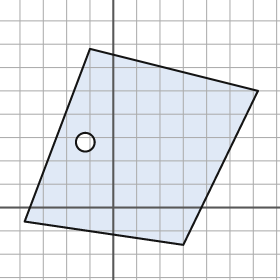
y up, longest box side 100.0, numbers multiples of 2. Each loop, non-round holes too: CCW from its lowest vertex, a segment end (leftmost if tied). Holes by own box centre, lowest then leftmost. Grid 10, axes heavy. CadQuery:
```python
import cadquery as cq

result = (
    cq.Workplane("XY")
    .moveTo(30.0, -16.0)
    .lineTo(62.0, 50.0)
    .lineTo(-10.0, 68.0)
    .lineTo(-38.0, -6.0)
    .close()
    .moveTo(-12.0, 28.0)
    .circle(4.0)
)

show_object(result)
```